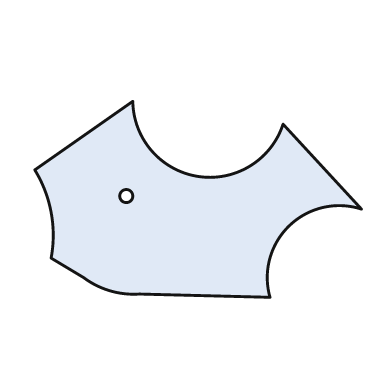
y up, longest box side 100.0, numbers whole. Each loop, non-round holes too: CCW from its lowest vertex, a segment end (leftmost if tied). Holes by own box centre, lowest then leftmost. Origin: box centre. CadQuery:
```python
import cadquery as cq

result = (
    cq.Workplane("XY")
    .moveTo(22.0, -30.0)
    .threePointArc((28.0, -8.0), (50.0, -3.0))
    .lineTo(26.0, 23.0)
    .threePointArc((0.0, 7.0), (-20.0, 30.0))
    .lineTo(-50.0, 9.0)
    .threePointArc((-45.0, -4.0), (-45.0, -18.0))
    .lineTo(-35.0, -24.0)
    .threePointArc((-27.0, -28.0), (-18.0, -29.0))
    .close()
    .moveTo(-22.0, 1.0)
    .circle(2.0)
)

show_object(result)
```